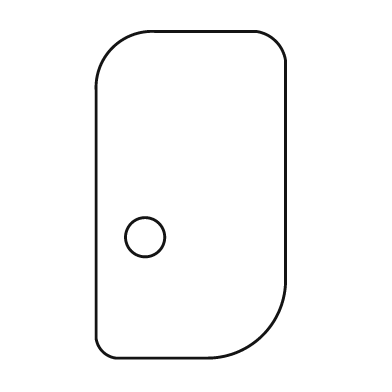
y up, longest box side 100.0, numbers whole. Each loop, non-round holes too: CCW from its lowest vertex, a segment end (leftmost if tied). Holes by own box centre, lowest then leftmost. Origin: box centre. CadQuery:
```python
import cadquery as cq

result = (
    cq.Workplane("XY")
    .moveTo(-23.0, -50.0)
    .lineTo(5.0, -50.0)
    .threePointArc((22.0, -43.0), (29.0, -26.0))
    .lineTo(29.0, 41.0)
    .threePointArc((26.0, 47.0), (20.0, 50.0))
    .lineTo(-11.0, 50.0)
    .threePointArc((-24.0, 45.0), (-29.0, 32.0))
    .lineTo(-29.0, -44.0)
    .threePointArc((-27.0, -48.0), (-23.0, -50.0))
    .close()
    .moveTo(-14.0, -13.0)
    .circle(6.0)
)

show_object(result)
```